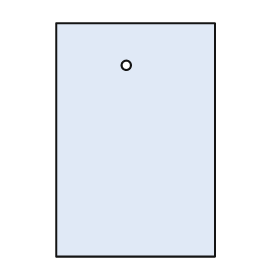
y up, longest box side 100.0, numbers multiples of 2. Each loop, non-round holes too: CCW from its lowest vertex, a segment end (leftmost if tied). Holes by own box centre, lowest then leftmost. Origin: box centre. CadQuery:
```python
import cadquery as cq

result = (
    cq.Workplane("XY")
    .moveTo(-34.0, -50.0)
    .lineTo(34.0, -50.0)
    .lineTo(34.0, 50.0)
    .lineTo(-34.0, 50.0)
    .close()
    .moveTo(-4.0, 32.0)
    .circle(2.0)
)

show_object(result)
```